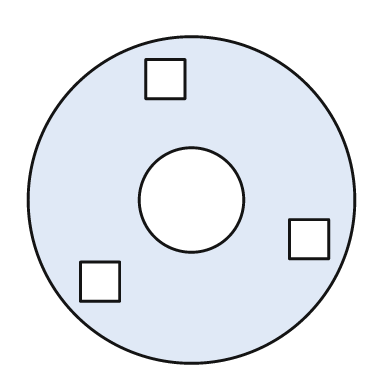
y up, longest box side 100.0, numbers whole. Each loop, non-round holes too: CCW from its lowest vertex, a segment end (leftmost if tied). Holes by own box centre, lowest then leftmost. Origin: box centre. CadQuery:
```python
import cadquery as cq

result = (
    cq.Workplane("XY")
    .moveTo(0.0, 0.0)
    .circle(50.0)
    .moveTo(-34.0, -31.0)
    .lineTo(-22.0, -31.0)
    .lineTo(-22.0, -19.0)
    .lineTo(-34.0, -19.0)
    .close()
    .moveTo(30.0, -18.0)
    .lineTo(42.0, -18.0)
    .lineTo(42.0, -6.0)
    .lineTo(30.0, -6.0)
    .close()
    .moveTo(0.0, 0.0)
    .circle(16.0)
    .moveTo(-14.0, 31.0)
    .lineTo(-2.0, 31.0)
    .lineTo(-2.0, 43.0)
    .lineTo(-14.0, 43.0)
    .close()
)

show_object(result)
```